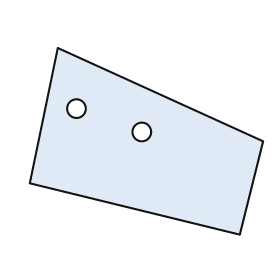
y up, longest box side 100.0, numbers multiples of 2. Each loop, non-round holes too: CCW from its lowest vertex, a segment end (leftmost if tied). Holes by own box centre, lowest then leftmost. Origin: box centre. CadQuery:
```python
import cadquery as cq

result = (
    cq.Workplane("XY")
    .moveTo(40.0, -40.0)
    .lineTo(50.0, 0.0)
    .lineTo(-38.0, 40.0)
    .lineTo(-50.0, -18.0)
    .close()
    .moveTo(-2.0, 4.0)
    .circle(4.0)
    .moveTo(-30.0, 14.0)
    .circle(4.0)
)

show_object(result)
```